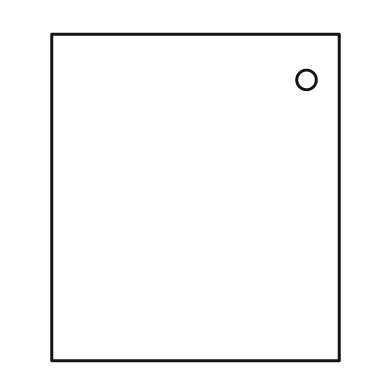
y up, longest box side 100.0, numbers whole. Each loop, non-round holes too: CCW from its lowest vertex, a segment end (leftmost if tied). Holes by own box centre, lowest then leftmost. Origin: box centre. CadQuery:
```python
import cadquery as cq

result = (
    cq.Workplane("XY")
    .moveTo(-44.0, -50.0)
    .lineTo(44.0, -50.0)
    .lineTo(44.0, 50.0)
    .lineTo(-44.0, 50.0)
    .close()
    .moveTo(34.0, 36.0)
    .circle(3.0)
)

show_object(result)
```